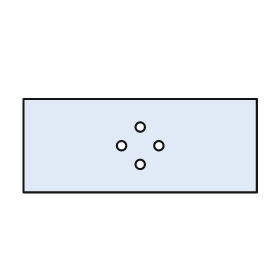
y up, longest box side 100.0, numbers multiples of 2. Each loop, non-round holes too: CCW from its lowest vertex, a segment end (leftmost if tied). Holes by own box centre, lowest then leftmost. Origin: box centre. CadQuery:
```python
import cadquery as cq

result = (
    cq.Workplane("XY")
    .moveTo(-50.0, -20.0)
    .lineTo(50.0, -20.0)
    .lineTo(50.0, 20.0)
    .lineTo(-50.0, 20.0)
    .close()
    .moveTo(0.0, -8.0)
    .circle(2.0)
    .moveTo(-8.0, 0.0)
    .circle(2.0)
    .moveTo(8.0, 0.0)
    .circle(2.0)
    .moveTo(0.0, 8.0)
    .circle(2.0)
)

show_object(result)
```